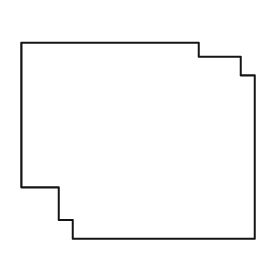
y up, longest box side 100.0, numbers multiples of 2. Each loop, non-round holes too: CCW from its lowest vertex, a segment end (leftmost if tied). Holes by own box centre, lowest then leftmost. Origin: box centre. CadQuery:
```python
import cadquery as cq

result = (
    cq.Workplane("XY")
    .moveTo(-28.0, -42.0)
    .lineTo(50.0, -42.0)
    .lineTo(50.0, 28.0)
    .lineTo(44.0, 28.0)
    .lineTo(44.0, 36.0)
    .lineTo(26.0, 36.0)
    .lineTo(26.0, 42.0)
    .lineTo(-50.0, 42.0)
    .lineTo(-50.0, -20.0)
    .lineTo(-34.0, -20.0)
    .lineTo(-34.0, -34.0)
    .lineTo(-28.0, -34.0)
    .close()
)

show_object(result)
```